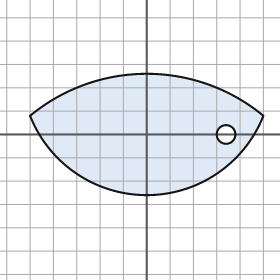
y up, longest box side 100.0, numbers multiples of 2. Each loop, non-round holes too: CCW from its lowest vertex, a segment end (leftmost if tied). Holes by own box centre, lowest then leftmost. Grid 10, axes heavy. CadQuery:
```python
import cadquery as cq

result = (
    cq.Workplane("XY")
    .moveTo(-50.0, 8.0)
    .threePointArc((0.0, -26.0), (50.0, 8.0))
    .threePointArc((0.0, 26.0), (-50.0, 8.0))
    .close()
    .moveTo(34.0, 0.0)
    .circle(4.0)
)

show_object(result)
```